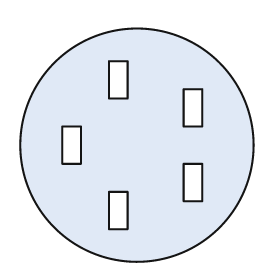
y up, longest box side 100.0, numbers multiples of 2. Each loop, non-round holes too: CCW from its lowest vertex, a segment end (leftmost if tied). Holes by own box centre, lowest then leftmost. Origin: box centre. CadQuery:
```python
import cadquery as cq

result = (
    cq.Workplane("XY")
    .moveTo(0.0, 0.0)
    .circle(50.0)
    .moveTo(-12.0, -36.0)
    .lineTo(-4.0, -36.0)
    .lineTo(-4.0, -20.0)
    .lineTo(-12.0, -20.0)
    .close()
    .moveTo(20.0, -24.0)
    .lineTo(28.0, -24.0)
    .lineTo(28.0, -8.0)
    .lineTo(20.0, -8.0)
    .close()
    .moveTo(-32.0, -8.0)
    .lineTo(-24.0, -8.0)
    .lineTo(-24.0, 8.0)
    .lineTo(-32.0, 8.0)
    .close()
    .moveTo(20.0, 8.0)
    .lineTo(28.0, 8.0)
    .lineTo(28.0, 24.0)
    .lineTo(20.0, 24.0)
    .close()
    .moveTo(-12.0, 20.0)
    .lineTo(-4.0, 20.0)
    .lineTo(-4.0, 36.0)
    .lineTo(-12.0, 36.0)
    .close()
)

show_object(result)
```